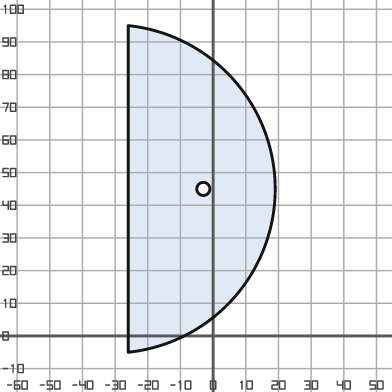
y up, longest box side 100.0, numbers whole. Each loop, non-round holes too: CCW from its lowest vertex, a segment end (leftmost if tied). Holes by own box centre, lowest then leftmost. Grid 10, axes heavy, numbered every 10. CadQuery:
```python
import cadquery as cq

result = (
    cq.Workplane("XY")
    .moveTo(-26.0, -5.0)
    .threePointArc((19.0, 45.0), (-26.0, 95.0))
    .close()
    .moveTo(-3.0, 45.0)
    .circle(2.0)
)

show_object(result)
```